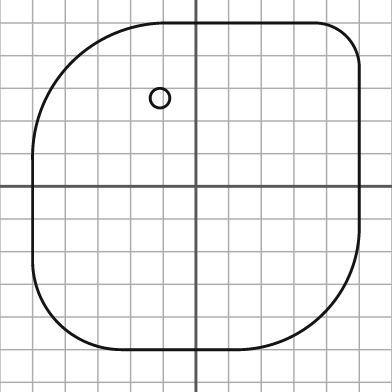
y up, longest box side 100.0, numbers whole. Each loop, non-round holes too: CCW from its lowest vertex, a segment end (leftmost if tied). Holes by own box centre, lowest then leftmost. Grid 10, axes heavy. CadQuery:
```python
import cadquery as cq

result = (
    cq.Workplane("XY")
    .moveTo(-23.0, -50.0)
    .lineTo(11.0, -50.0)
    .threePointArc((39.0, -39.0), (50.0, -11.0))
    .lineTo(50.0, 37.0)
    .threePointArc((46.0, 46.0), (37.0, 50.0))
    .lineTo(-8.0, 50.0)
    .threePointArc((-38.0, 38.0), (-50.0, 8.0))
    .lineTo(-50.0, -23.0)
    .threePointArc((-42.0, -42.0), (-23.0, -50.0))
    .close()
    .moveTo(-11.0, 27.0)
    .circle(3.0)
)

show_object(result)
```